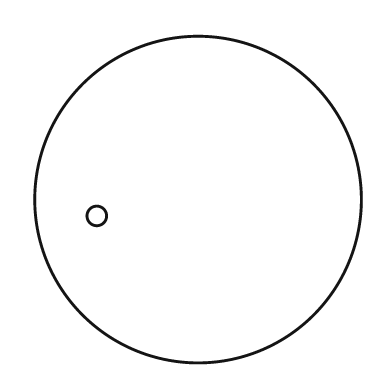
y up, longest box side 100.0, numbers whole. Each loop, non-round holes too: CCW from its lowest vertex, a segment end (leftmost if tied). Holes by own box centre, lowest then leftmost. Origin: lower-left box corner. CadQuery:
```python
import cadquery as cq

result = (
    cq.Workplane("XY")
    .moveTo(50.0, 50.0)
    .circle(50.0)
    .moveTo(19.0, 45.0)
    .circle(3.0)
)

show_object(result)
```